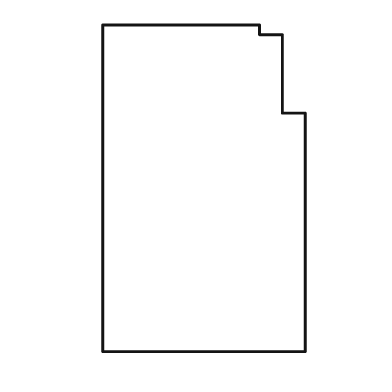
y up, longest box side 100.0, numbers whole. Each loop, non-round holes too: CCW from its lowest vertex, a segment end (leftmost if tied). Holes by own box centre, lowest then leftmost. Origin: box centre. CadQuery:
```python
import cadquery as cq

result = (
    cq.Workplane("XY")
    .moveTo(-31.0, -50.0)
    .lineTo(31.0, -50.0)
    .lineTo(31.0, 23.0)
    .lineTo(24.0, 23.0)
    .lineTo(24.0, 47.0)
    .lineTo(17.0, 47.0)
    .lineTo(17.0, 50.0)
    .lineTo(-31.0, 50.0)
    .close()
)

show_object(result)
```